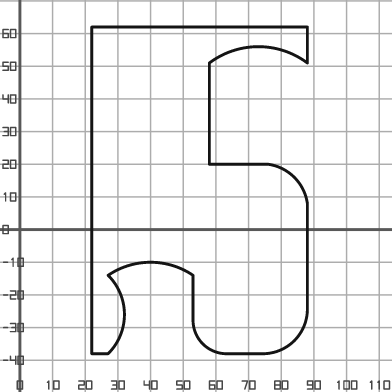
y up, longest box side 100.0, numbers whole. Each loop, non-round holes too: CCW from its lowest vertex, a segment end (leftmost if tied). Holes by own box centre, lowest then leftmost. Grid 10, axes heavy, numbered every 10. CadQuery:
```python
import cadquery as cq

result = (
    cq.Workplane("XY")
    .moveTo(22.0, -38.0)
    .lineTo(27.0, -38.0)
    .threePointArc((32.0, -26.0), (27.0, -14.0))
    .threePointArc((40.0, -10.0), (53.0, -14.0))
    .lineTo(53.0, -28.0)
    .threePointArc((56.0, -35.0), (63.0, -38.0))
    .lineTo(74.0, -38.0)
    .threePointArc((84.0, -34.0), (88.0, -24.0))
    .lineTo(88.0, 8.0)
    .threePointArc((84.0, 16.0), (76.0, 20.0))
    .lineTo(58.0, 20.0)
    .lineTo(58.0, 51.0)
    .threePointArc((73.0, 56.0), (88.0, 51.0))
    .lineTo(88.0, 62.0)
    .lineTo(22.0, 62.0)
    .close()
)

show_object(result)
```